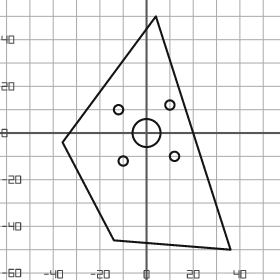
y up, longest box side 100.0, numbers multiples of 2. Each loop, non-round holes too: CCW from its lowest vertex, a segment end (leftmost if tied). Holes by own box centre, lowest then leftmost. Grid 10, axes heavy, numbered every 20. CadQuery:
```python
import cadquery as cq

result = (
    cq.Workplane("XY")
    .moveTo(36.0, -50.0)
    .lineTo(4.0, 50.0)
    .lineTo(-36.0, -4.0)
    .lineTo(-14.0, -46.0)
    .close()
    .moveTo(-10.0, -12.0)
    .circle(2.0)
    .moveTo(12.0, -10.0)
    .circle(2.0)
    .moveTo(0.0, 0.0)
    .circle(6.0)
    .moveTo(-12.0, 10.0)
    .circle(2.0)
    .moveTo(10.0, 12.0)
    .circle(2.0)
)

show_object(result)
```